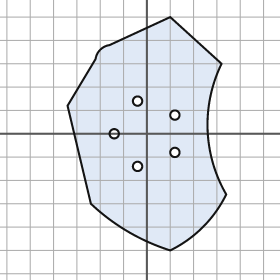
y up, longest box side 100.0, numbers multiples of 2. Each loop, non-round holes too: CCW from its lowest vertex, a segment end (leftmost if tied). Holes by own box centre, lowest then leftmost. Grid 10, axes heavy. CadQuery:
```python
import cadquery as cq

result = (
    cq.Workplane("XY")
    .moveTo(10.0, -50.0)
    .threePointArc((24.0, -40.0), (34.0, -26.0))
    .threePointArc((26.0, 2.0), (32.0, 30.0))
    .lineTo(10.0, 50.0)
    .lineTo(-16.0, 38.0)
    .threePointArc((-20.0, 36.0), (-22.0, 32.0))
    .lineTo(-34.0, 12.0)
    .lineTo(-24.0, -30.0)
    .threePointArc((-8.0, -42.0), (10.0, -50.0))
    .close()
    .moveTo(-4.0, -14.0)
    .circle(2.0)
    .moveTo(12.0, -8.0)
    .circle(2.0)
    .moveTo(-14.0, 0.0)
    .circle(2.0)
    .moveTo(12.0, 8.0)
    .circle(2.0)
    .moveTo(-4.0, 14.0)
    .circle(2.0)
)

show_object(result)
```